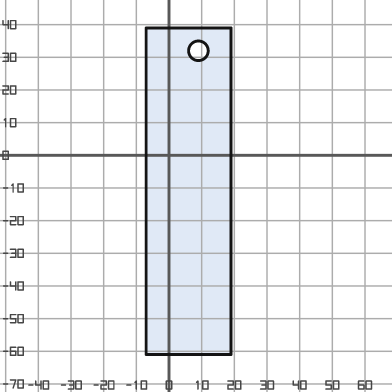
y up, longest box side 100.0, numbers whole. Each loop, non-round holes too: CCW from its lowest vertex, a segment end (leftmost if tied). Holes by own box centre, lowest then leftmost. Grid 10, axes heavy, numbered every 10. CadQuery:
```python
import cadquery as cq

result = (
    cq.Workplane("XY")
    .moveTo(-7.0, -61.0)
    .lineTo(19.0, -61.0)
    .lineTo(19.0, 39.0)
    .lineTo(-7.0, 39.0)
    .close()
    .moveTo(9.0, 32.0)
    .circle(3.0)
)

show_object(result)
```